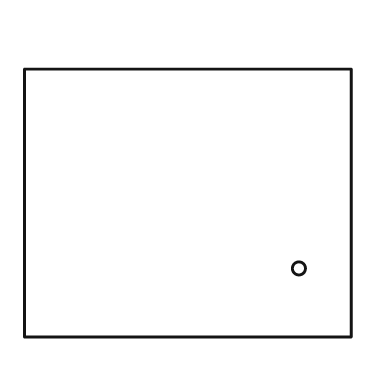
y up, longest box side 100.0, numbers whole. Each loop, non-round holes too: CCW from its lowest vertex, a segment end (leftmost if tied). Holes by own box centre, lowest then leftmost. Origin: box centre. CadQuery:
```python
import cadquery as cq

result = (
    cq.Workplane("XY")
    .moveTo(-50.0, -41.0)
    .lineTo(50.0, -41.0)
    .lineTo(50.0, 41.0)
    .lineTo(-50.0, 41.0)
    .close()
    .moveTo(34.0, -20.0)
    .circle(2.0)
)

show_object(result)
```